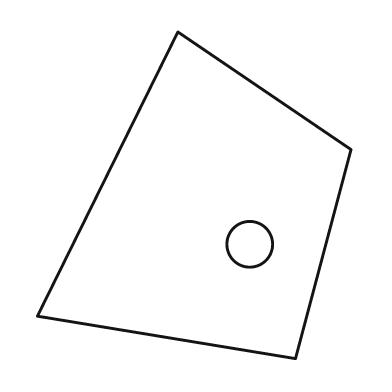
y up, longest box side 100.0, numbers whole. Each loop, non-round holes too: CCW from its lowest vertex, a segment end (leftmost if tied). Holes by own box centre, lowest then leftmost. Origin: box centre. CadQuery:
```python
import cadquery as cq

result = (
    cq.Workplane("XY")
    .moveTo(31.0, -50.0)
    .lineTo(48.0, 14.0)
    .lineTo(-5.0, 50.0)
    .lineTo(-48.0, -37.0)
    .close()
    .moveTo(17.0, -15.0)
    .circle(7.0)
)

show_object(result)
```